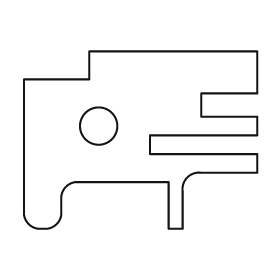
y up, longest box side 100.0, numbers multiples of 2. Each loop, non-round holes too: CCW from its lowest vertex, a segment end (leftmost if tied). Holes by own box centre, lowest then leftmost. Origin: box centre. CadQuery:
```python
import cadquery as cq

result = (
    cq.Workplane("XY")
    .moveTo(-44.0, -38.0)
    .lineTo(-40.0, -38.0)
    .threePointArc((-36.0, -36.0), (-34.0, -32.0))
    .lineTo(-34.0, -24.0)
    .threePointArc((-32.0, -20.0), (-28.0, -18.0))
    .lineTo(12.0, -18.0)
    .lineTo(12.0, -38.0)
    .lineTo(18.0, -38.0)
    .lineTo(18.0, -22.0)
    .threePointArc((20.0, -16.0), (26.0, -14.0))
    .lineTo(50.0, -14.0)
    .lineTo(50.0, -6.0)
    .lineTo(4.0, -6.0)
    .lineTo(4.0, 2.0)
    .lineTo(50.0, 2.0)
    .lineTo(50.0, 10.0)
    .lineTo(26.0, 10.0)
    .lineTo(26.0, 20.0)
    .lineTo(50.0, 20.0)
    .lineTo(50.0, 38.0)
    .lineTo(-22.0, 38.0)
    .lineTo(-22.0, 26.0)
    .lineTo(-50.0, 26.0)
    .lineTo(-50.0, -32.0)
    .threePointArc((-48.0, -36.0), (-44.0, -38.0))
    .close()
    .moveTo(-18.0, 6.0)
    .circle(8.0)
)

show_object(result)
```